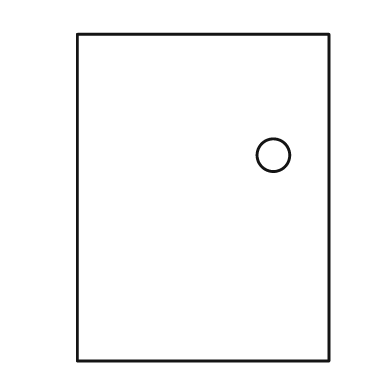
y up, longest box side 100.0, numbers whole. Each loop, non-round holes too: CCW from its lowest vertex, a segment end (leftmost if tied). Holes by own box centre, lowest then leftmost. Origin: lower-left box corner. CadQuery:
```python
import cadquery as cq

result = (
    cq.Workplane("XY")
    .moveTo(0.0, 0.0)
    .lineTo(77.0, 0.0)
    .lineTo(77.0, 100.0)
    .lineTo(0.0, 100.0)
    .close()
    .moveTo(60.0, 63.0)
    .circle(5.0)
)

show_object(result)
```